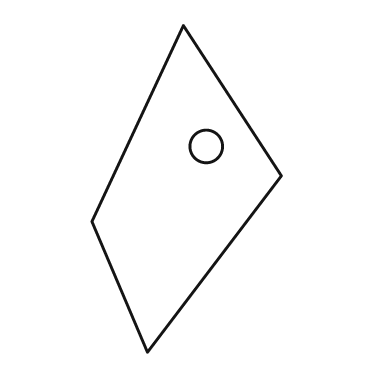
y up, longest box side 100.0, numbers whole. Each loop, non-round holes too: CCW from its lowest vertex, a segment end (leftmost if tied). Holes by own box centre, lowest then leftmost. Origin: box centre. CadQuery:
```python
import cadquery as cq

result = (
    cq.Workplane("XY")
    .moveTo(-12.0, -50.0)
    .lineTo(29.0, 4.0)
    .lineTo(-1.0, 50.0)
    .lineTo(-29.0, -10.0)
    .close()
    .moveTo(6.0, 13.0)
    .circle(5.0)
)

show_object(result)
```